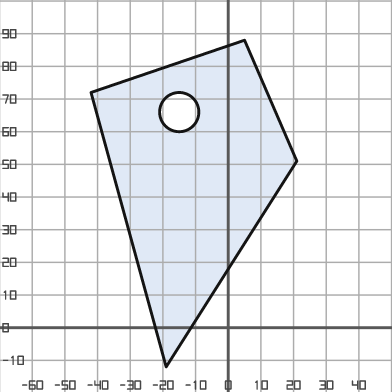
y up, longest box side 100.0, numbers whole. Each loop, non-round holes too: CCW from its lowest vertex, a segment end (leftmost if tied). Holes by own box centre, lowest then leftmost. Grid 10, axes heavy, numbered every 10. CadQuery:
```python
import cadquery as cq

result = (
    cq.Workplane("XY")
    .moveTo(-19.0, -12.0)
    .lineTo(21.0, 51.0)
    .lineTo(5.0, 88.0)
    .lineTo(-42.0, 72.0)
    .close()
    .moveTo(-15.0, 66.0)
    .circle(6.0)
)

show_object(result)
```